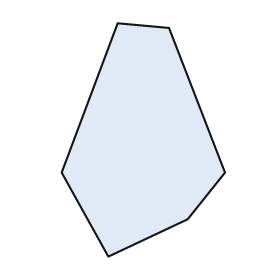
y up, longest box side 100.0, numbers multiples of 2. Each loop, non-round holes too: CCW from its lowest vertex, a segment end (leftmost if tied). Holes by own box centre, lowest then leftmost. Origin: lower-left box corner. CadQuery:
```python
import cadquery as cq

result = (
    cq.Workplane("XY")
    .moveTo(20.0, 0.0)
    .lineTo(54.0, 16.0)
    .lineTo(70.0, 36.0)
    .lineTo(46.0, 98.0)
    .lineTo(24.0, 100.0)
    .lineTo(0.0, 36.0)
    .close()
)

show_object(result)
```